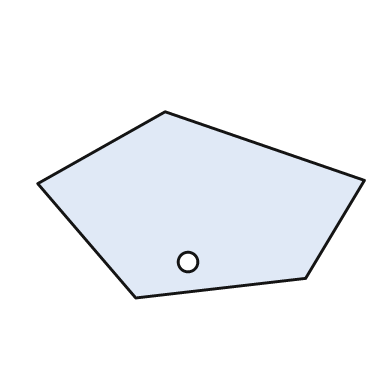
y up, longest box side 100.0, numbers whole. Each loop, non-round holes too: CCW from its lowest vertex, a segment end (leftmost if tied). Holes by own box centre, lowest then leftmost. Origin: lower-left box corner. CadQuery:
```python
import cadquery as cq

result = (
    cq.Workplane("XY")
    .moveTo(30.0, 0.0)
    .lineTo(82.0, 6.0)
    .lineTo(100.0, 36.0)
    .lineTo(39.0, 57.0)
    .lineTo(0.0, 35.0)
    .close()
    .moveTo(46.0, 11.0)
    .circle(3.0)
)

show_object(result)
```